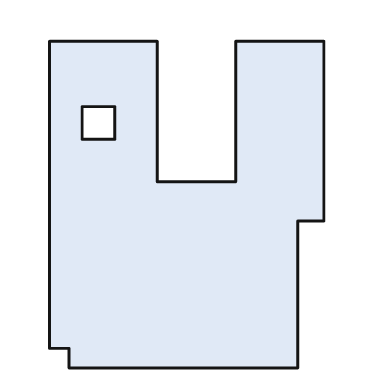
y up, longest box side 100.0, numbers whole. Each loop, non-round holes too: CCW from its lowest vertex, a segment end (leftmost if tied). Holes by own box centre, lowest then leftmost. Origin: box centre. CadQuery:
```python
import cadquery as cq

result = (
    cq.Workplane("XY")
    .moveTo(-36.0, -50.0)
    .lineTo(34.0, -50.0)
    .lineTo(34.0, -5.0)
    .lineTo(42.0, -5.0)
    .lineTo(42.0, 50.0)
    .lineTo(15.0, 50.0)
    .lineTo(15.0, 7.0)
    .lineTo(-9.0, 7.0)
    .lineTo(-9.0, 50.0)
    .lineTo(-42.0, 50.0)
    .lineTo(-42.0, -44.0)
    .lineTo(-36.0, -44.0)
    .close()
    .moveTo(-32.0, 20.0)
    .lineTo(-22.0, 20.0)
    .lineTo(-22.0, 30.0)
    .lineTo(-32.0, 30.0)
    .close()
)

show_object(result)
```